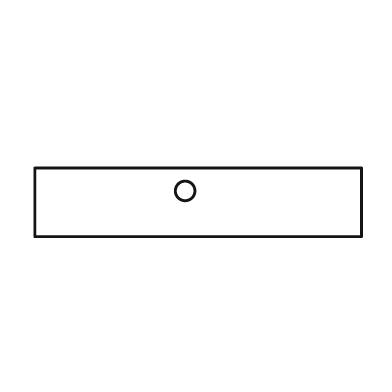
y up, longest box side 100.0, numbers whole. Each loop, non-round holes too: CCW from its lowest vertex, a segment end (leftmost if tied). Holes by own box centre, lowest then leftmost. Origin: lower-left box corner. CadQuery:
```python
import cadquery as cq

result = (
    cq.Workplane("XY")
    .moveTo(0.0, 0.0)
    .lineTo(100.0, 0.0)
    .lineTo(100.0, 21.0)
    .lineTo(0.0, 21.0)
    .close()
    .moveTo(46.0, 14.0)
    .circle(3.0)
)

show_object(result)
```